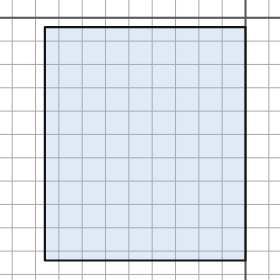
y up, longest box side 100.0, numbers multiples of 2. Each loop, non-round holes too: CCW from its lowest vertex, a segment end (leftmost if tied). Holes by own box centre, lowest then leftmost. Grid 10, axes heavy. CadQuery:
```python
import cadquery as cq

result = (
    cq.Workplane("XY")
    .moveTo(-86.0, -104.0)
    .lineTo(0.0, -104.0)
    .lineTo(0.0, -4.0)
    .lineTo(-86.0, -4.0)
    .close()
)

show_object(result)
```